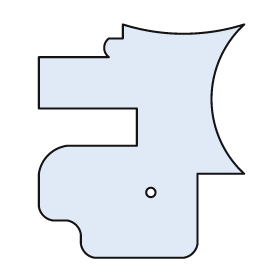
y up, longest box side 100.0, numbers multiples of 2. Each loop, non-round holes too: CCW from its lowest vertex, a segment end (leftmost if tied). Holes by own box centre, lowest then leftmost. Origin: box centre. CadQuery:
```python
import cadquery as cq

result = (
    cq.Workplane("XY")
    .moveTo(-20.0, -50.0)
    .lineTo(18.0, -50.0)
    .threePointArc((22.0, -48.0), (24.0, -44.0))
    .lineTo(24.0, -14.0)
    .lineTo(44.0, -14.0)
    .threePointArc((30.0, 18.0), (44.0, 50.0))
    .threePointArc((18.0, 46.0), (-8.0, 50.0))
    .lineTo(-8.0, 44.0)
    .lineTo(-14.0, 44.0)
    .threePointArc((-16.0, 40.0), (-14.0, 36.0))
    .lineTo(-44.0, 36.0)
    .lineTo(-44.0, 14.0)
    .lineTo(-2.0, 14.0)
    .lineTo(-2.0, -2.0)
    .lineTo(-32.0, -2.0)
    .threePointArc((-40.0, -6.0), (-44.0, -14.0))
    .lineTo(-44.0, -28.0)
    .threePointArc((-42.0, -32.0), (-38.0, -34.0))
    .lineTo(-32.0, -34.0)
    .threePointArc((-28.0, -36.0), (-26.0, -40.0))
    .lineTo(-26.0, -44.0)
    .threePointArc((-24.0, -48.0), (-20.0, -50.0))
    .close()
    .moveTo(4.0, -22.0)
    .circle(2.0)
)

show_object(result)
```